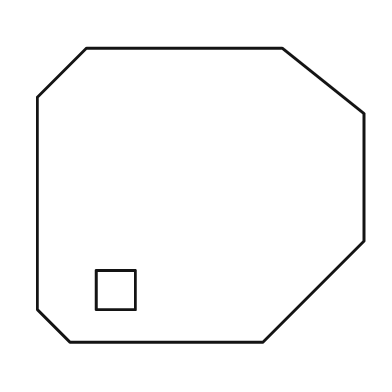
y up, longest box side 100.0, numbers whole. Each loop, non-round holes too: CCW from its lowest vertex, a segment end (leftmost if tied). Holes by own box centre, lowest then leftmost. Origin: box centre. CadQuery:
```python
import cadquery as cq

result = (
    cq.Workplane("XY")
    .moveTo(-40.0, -45.0)
    .lineTo(19.0, -45.0)
    .lineTo(50.0, -14.0)
    .lineTo(50.0, 25.0)
    .lineTo(25.0, 45.0)
    .lineTo(-35.0, 45.0)
    .lineTo(-50.0, 30.0)
    .lineTo(-50.0, -35.0)
    .close()
    .moveTo(-32.0, -35.0)
    .lineTo(-20.0, -35.0)
    .lineTo(-20.0, -23.0)
    .lineTo(-32.0, -23.0)
    .close()
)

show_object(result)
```